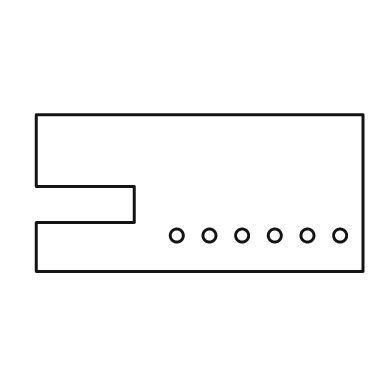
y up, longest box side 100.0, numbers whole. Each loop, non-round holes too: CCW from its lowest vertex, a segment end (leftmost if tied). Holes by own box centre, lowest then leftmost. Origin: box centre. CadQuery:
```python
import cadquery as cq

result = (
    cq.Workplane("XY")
    .moveTo(-50.0, -24.0)
    .lineTo(50.0, -24.0)
    .lineTo(50.0, 24.0)
    .lineTo(-50.0, 24.0)
    .lineTo(-50.0, 2.0)
    .lineTo(-20.0, 2.0)
    .lineTo(-20.0, -9.0)
    .lineTo(-50.0, -9.0)
    .close()
    .moveTo(-7.0, -13.0)
    .circle(2.0)
    .moveTo(3.0, -13.0)
    .circle(2.0)
    .moveTo(13.0, -13.0)
    .circle(2.0)
    .moveTo(23.0, -13.0)
    .circle(2.0)
    .moveTo(33.0, -13.0)
    .circle(2.0)
    .moveTo(43.0, -13.0)
    .circle(2.0)
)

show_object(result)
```